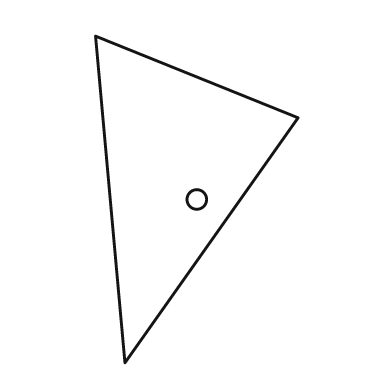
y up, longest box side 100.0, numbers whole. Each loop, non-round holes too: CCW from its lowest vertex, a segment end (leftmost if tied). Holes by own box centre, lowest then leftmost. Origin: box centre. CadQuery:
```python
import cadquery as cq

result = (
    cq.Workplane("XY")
    .moveTo(-22.0, -50.0)
    .lineTo(31.0, 25.0)
    .lineTo(-31.0, 50.0)
    .close()
    .moveTo(0.0, 0.0)
    .circle(3.0)
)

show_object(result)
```